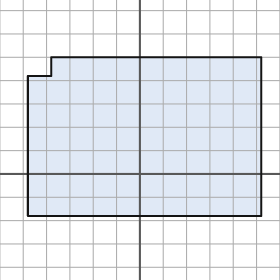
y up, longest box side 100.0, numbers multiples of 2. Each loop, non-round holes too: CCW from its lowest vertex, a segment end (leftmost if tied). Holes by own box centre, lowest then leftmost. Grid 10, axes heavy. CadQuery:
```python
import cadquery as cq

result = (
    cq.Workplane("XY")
    .moveTo(-48.0, -18.0)
    .lineTo(52.0, -18.0)
    .lineTo(52.0, 50.0)
    .lineTo(-38.0, 50.0)
    .lineTo(-38.0, 42.0)
    .lineTo(-48.0, 42.0)
    .close()
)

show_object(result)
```